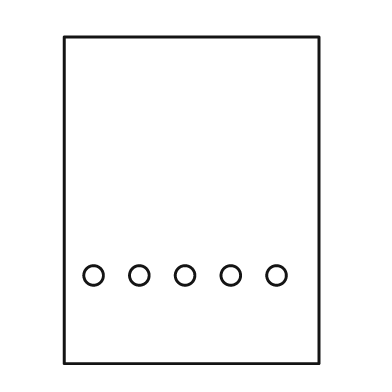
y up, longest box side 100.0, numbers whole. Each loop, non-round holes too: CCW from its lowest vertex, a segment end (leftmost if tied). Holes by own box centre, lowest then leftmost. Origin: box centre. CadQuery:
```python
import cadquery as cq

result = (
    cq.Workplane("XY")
    .moveTo(-39.0, -50.0)
    .lineTo(39.0, -50.0)
    .lineTo(39.0, 50.0)
    .lineTo(-39.0, 50.0)
    .close()
    .moveTo(-30.0, -23.0)
    .circle(3.0)
    .moveTo(-16.0, -23.0)
    .circle(3.0)
    .moveTo(-2.0, -23.0)
    .circle(3.0)
    .moveTo(12.0, -23.0)
    .circle(3.0)
    .moveTo(26.0, -23.0)
    .circle(3.0)
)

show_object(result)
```